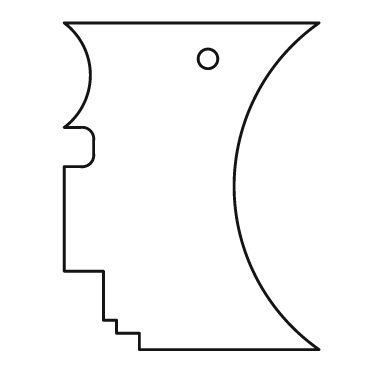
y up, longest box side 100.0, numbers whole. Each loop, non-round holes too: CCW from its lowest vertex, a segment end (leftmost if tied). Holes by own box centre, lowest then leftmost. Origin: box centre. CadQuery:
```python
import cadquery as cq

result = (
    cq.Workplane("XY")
    .moveTo(-16.0, -50.0)
    .lineTo(39.0, -50.0)
    .threePointArc((13.0, 0.0), (39.0, 50.0))
    .lineTo(-39.0, 50.0)
    .threePointArc((-31.0, 34.0), (-39.0, 18.0))
    .lineTo(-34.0, 18.0)
    .threePointArc((-31.0, 17.0), (-30.0, 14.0))
    .lineTo(-30.0, 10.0)
    .threePointArc((-31.0, 7.0), (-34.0, 6.0))
    .lineTo(-39.0, 6.0)
    .lineTo(-39.0, -26.0)
    .lineTo(-27.0, -26.0)
    .lineTo(-27.0, -41.0)
    .lineTo(-23.0, -41.0)
    .lineTo(-23.0, -45.0)
    .lineTo(-16.0, -45.0)
    .close()
    .moveTo(5.0, 39.0)
    .circle(3.0)
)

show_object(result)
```